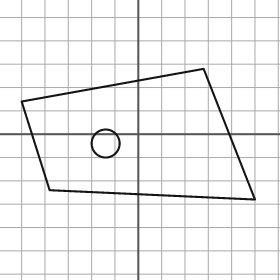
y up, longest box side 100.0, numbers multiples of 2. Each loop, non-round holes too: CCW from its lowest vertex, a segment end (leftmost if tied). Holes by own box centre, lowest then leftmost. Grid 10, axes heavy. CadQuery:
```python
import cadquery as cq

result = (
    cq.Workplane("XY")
    .moveTo(50.0, -28.0)
    .lineTo(28.0, 28.0)
    .lineTo(-50.0, 14.0)
    .lineTo(-38.0, -24.0)
    .close()
    .moveTo(-14.0, -4.0)
    .circle(6.0)
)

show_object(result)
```